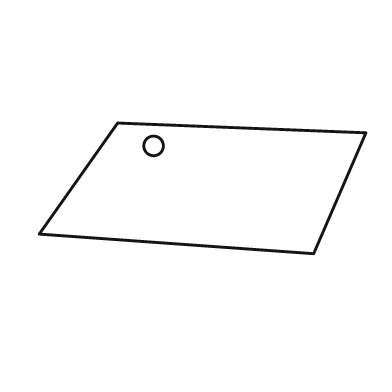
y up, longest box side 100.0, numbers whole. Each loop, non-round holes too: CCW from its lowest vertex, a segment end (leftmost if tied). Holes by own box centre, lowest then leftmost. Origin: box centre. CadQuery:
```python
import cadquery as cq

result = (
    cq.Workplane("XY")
    .moveTo(34.0, -20.0)
    .lineTo(50.0, 17.0)
    .lineTo(-26.0, 20.0)
    .lineTo(-50.0, -14.0)
    .close()
    .moveTo(-15.0, 13.0)
    .circle(3.0)
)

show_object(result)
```